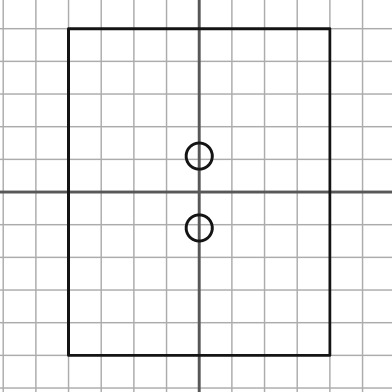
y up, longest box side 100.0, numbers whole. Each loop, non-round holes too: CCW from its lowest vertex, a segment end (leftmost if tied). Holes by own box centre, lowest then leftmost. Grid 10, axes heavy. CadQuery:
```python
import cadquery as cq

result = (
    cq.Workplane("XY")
    .moveTo(-40.0, -50.0)
    .lineTo(40.0, -50.0)
    .lineTo(40.0, 50.0)
    .lineTo(-40.0, 50.0)
    .close()
    .moveTo(0.0, -11.0)
    .circle(4.0)
    .moveTo(0.0, 11.0)
    .circle(4.0)
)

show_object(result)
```